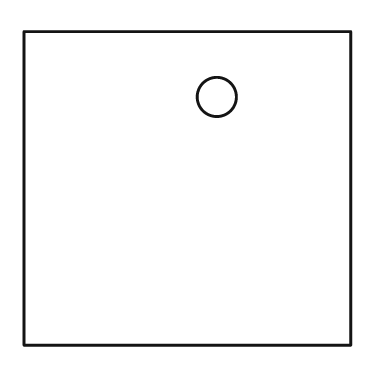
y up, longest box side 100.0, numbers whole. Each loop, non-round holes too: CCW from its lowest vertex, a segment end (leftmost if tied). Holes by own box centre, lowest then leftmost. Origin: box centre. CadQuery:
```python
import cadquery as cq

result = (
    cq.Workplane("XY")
    .moveTo(-50.0, -48.0)
    .lineTo(50.0, -48.0)
    .lineTo(50.0, 48.0)
    .lineTo(-50.0, 48.0)
    .close()
    .moveTo(9.0, 28.0)
    .circle(6.0)
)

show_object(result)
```